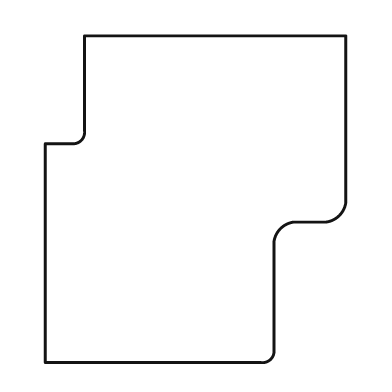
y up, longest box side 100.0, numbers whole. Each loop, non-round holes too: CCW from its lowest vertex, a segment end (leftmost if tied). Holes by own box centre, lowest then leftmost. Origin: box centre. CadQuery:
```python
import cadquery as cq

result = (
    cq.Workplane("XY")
    .moveTo(-46.0, -50.0)
    .lineTo(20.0, -50.0)
    .threePointArc((23.0, -49.0), (24.0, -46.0))
    .lineTo(24.0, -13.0)
    .threePointArc((26.0, -9.0), (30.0, -7.0))
    .lineTo(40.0, -7.0)
    .threePointArc((44.0, -5.0), (46.0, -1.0))
    .lineTo(46.0, 50.0)
    .lineTo(-34.0, 50.0)
    .lineTo(-34.0, 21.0)
    .threePointArc((-35.0, 18.0), (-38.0, 17.0))
    .lineTo(-46.0, 17.0)
    .close()
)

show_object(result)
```